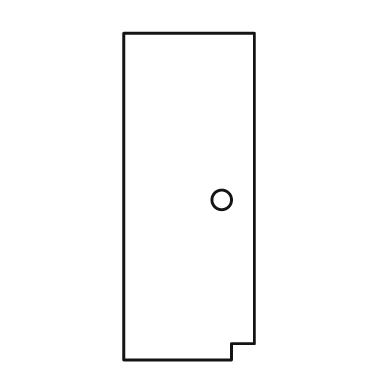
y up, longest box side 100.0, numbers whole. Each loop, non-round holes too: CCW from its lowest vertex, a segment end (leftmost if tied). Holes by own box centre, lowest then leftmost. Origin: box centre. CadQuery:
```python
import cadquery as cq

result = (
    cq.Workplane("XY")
    .moveTo(-20.0, -50.0)
    .lineTo(13.0, -50.0)
    .lineTo(13.0, -45.0)
    .lineTo(20.0, -45.0)
    .lineTo(20.0, 50.0)
    .lineTo(-20.0, 50.0)
    .close()
    .moveTo(10.0, -1.0)
    .circle(3.0)
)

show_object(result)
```